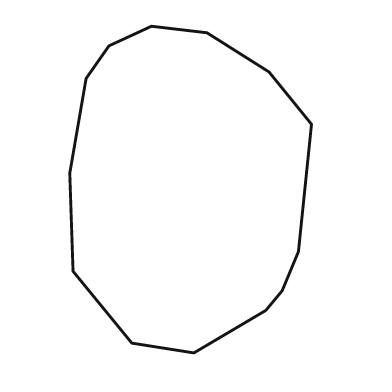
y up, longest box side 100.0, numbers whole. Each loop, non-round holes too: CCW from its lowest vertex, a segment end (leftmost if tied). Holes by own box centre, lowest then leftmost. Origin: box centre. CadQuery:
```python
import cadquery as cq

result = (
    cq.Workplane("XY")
    .moveTo(1.0, -50.0)
    .lineTo(23.0, -37.0)
    .lineTo(28.0, -31.0)
    .lineTo(33.0, -19.0)
    .lineTo(37.0, 20.0)
    .lineTo(24.0, 36.0)
    .lineTo(5.0, 48.0)
    .lineTo(-12.0, 50.0)
    .lineTo(-25.0, 44.0)
    .lineTo(-32.0, 34.0)
    .lineTo(-37.0, 5.0)
    .lineTo(-36.0, -25.0)
    .lineTo(-18.0, -47.0)
    .close()
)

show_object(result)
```